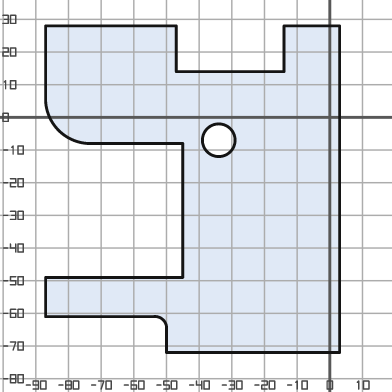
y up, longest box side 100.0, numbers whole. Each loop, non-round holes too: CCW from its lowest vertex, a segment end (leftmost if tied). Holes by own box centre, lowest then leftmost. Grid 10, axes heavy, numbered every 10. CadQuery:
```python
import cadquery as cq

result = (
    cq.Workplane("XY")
    .moveTo(-50.0, -72.0)
    .lineTo(3.0, -72.0)
    .lineTo(3.0, 28.0)
    .lineTo(-14.0, 28.0)
    .lineTo(-14.0, 14.0)
    .lineTo(-47.0, 14.0)
    .lineTo(-47.0, 28.0)
    .lineTo(-87.0, 28.0)
    .lineTo(-87.0, 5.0)
    .threePointArc((-83.0, -4.0), (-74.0, -8.0))
    .lineTo(-45.0, -8.0)
    .lineTo(-45.0, -49.0)
    .lineTo(-87.0, -49.0)
    .lineTo(-87.0, -61.0)
    .lineTo(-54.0, -61.0)
    .threePointArc((-51.0, -62.0), (-50.0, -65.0))
    .close()
    .moveTo(-34.0, -7.0)
    .circle(5.0)
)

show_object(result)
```